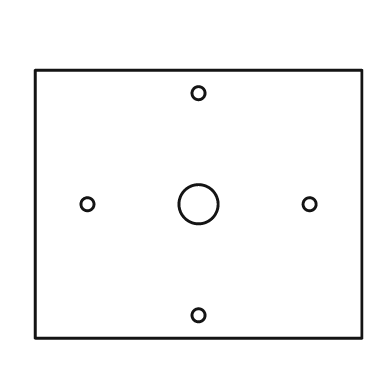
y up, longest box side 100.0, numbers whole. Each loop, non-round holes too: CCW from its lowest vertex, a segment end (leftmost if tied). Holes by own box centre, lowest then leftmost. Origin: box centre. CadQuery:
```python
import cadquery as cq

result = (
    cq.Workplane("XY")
    .moveTo(-50.0, -41.0)
    .lineTo(50.0, -41.0)
    .lineTo(50.0, 41.0)
    .lineTo(-50.0, 41.0)
    .close()
    .moveTo(0.0, -34.0)
    .circle(2.0)
    .moveTo(-34.0, 0.0)
    .circle(2.0)
    .moveTo(0.0, 0.0)
    .circle(6.0)
    .moveTo(34.0, 0.0)
    .circle(2.0)
    .moveTo(0.0, 34.0)
    .circle(2.0)
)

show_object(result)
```